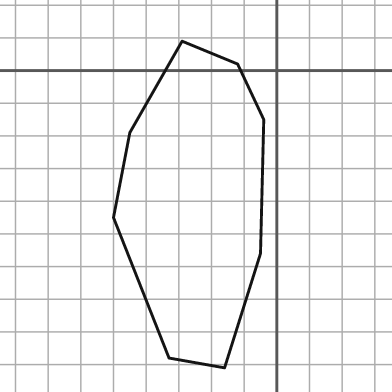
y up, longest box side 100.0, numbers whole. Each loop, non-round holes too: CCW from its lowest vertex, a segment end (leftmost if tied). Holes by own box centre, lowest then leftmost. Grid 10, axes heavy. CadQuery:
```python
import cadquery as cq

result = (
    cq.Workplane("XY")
    .moveTo(-16.0, -91.0)
    .lineTo(-5.0, -56.0)
    .lineTo(-4.0, -15.0)
    .lineTo(-12.0, 2.0)
    .lineTo(-29.0, 9.0)
    .lineTo(-45.0, -19.0)
    .lineTo(-50.0, -45.0)
    .lineTo(-33.0, -88.0)
    .close()
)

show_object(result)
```